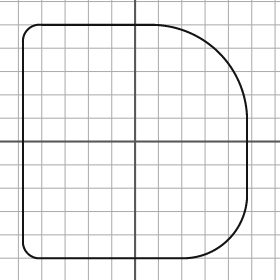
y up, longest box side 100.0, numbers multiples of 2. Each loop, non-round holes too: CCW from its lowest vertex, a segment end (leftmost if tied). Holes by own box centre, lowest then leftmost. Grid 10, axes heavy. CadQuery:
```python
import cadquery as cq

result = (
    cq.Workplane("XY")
    .moveTo(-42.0, -50.0)
    .lineTo(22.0, -50.0)
    .threePointArc((40.0, -42.0), (48.0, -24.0))
    .lineTo(48.0, 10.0)
    .threePointArc((36.0, 38.0), (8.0, 50.0))
    .lineTo(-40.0, 50.0)
    .threePointArc((-46.0, 48.0), (-48.0, 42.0))
    .lineTo(-48.0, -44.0)
    .threePointArc((-46.0, -48.0), (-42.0, -50.0))
    .close()
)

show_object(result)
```